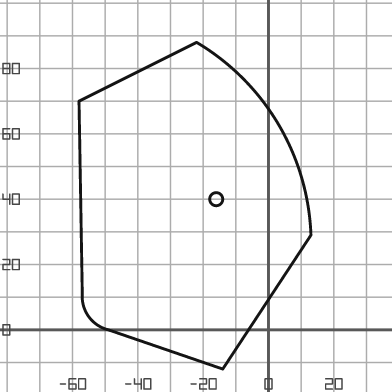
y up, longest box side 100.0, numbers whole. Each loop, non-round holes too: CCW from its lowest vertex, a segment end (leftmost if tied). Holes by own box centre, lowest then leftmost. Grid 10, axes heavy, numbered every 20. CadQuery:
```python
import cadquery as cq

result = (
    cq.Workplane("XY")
    .moveTo(-14.0, -12.0)
    .lineTo(13.0, 29.0)
    .threePointArc((3.0, 63.0), (-22.0, 88.0))
    .lineTo(-58.0, 70.0)
    .lineTo(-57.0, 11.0)
    .threePointArc((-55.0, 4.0), (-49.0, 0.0))
    .close()
    .moveTo(-16.0, 40.0)
    .circle(2.0)
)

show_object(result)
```